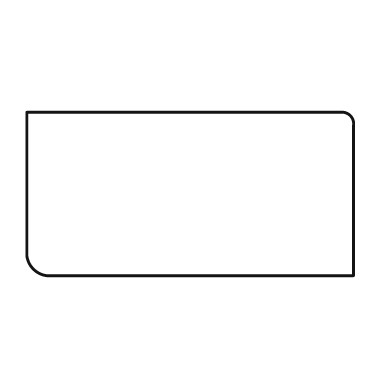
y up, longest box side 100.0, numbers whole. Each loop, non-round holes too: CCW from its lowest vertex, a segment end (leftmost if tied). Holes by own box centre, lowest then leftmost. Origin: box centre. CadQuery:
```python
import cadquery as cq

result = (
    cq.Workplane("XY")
    .moveTo(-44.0, -25.0)
    .lineTo(50.0, -25.0)
    .lineTo(50.0, 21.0)
    .threePointArc((49.0, 24.0), (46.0, 25.0))
    .lineTo(-50.0, 25.0)
    .lineTo(-50.0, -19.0)
    .threePointArc((-48.0, -23.0), (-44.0, -25.0))
    .close()
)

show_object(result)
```